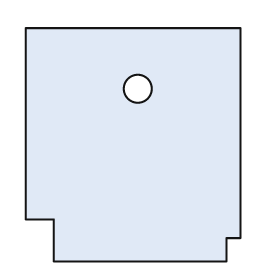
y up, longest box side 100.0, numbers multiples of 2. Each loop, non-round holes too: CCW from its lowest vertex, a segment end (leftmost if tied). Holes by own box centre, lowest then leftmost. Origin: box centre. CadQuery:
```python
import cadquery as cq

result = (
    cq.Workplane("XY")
    .moveTo(-34.0, -50.0)
    .lineTo(40.0, -50.0)
    .lineTo(40.0, -40.0)
    .lineTo(46.0, -40.0)
    .lineTo(46.0, 50.0)
    .lineTo(-46.0, 50.0)
    .lineTo(-46.0, -32.0)
    .lineTo(-34.0, -32.0)
    .close()
    .moveTo(2.0, 24.0)
    .circle(6.0)
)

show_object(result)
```